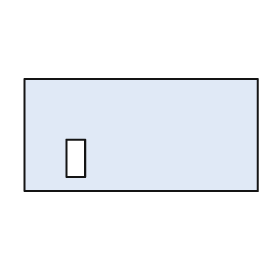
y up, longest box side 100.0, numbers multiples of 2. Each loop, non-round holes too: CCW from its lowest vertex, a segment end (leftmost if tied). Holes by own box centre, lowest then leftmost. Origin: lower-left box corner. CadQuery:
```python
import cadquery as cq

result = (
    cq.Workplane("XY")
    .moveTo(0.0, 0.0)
    .lineTo(100.0, 0.0)
    .lineTo(100.0, 48.0)
    .lineTo(0.0, 48.0)
    .close()
    .moveTo(18.0, 6.0)
    .lineTo(26.0, 6.0)
    .lineTo(26.0, 22.0)
    .lineTo(18.0, 22.0)
    .close()
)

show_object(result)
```